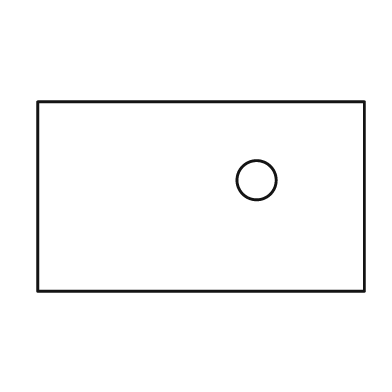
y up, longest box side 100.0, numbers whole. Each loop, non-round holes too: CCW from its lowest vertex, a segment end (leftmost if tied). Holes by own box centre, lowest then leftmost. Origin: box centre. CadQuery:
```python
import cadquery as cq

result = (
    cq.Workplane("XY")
    .moveTo(-50.0, -29.0)
    .lineTo(50.0, -29.0)
    .lineTo(50.0, 29.0)
    .lineTo(-50.0, 29.0)
    .close()
    .moveTo(17.0, 5.0)
    .circle(6.0)
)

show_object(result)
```